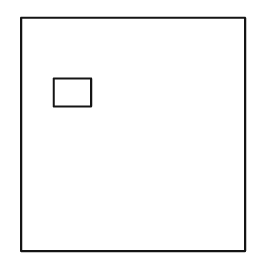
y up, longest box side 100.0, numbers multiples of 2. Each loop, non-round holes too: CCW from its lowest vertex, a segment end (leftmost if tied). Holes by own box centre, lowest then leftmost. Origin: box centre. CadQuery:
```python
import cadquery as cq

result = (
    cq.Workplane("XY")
    .moveTo(-48.0, -50.0)
    .lineTo(48.0, -50.0)
    .lineTo(48.0, 50.0)
    .lineTo(-48.0, 50.0)
    .close()
    .moveTo(-34.0, 12.0)
    .lineTo(-18.0, 12.0)
    .lineTo(-18.0, 24.0)
    .lineTo(-34.0, 24.0)
    .close()
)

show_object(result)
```